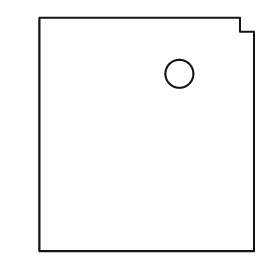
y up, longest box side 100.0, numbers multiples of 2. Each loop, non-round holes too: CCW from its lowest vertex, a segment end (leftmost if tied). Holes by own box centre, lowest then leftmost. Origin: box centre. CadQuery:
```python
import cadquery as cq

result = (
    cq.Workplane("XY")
    .moveTo(-46.0, -50.0)
    .lineTo(46.0, -50.0)
    .lineTo(46.0, 44.0)
    .lineTo(40.0, 44.0)
    .lineTo(40.0, 50.0)
    .lineTo(-46.0, 50.0)
    .close()
    .moveTo(14.0, 26.0)
    .circle(6.0)
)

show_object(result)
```